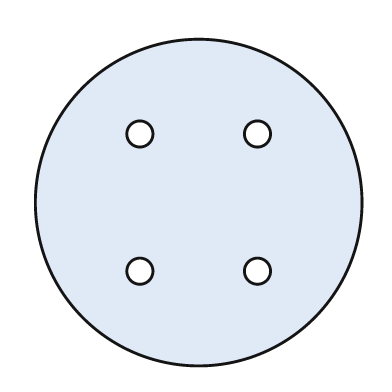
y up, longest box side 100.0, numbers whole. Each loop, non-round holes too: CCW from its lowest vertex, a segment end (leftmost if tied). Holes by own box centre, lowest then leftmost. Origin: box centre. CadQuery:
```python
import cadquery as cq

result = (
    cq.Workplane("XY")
    .moveTo(0.0, 0.0)
    .circle(50.0)
    .moveTo(-18.0, -21.0)
    .circle(4.0)
    .moveTo(18.0, -21.0)
    .circle(4.0)
    .moveTo(-18.0, 21.0)
    .circle(4.0)
    .moveTo(18.0, 21.0)
    .circle(4.0)
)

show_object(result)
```